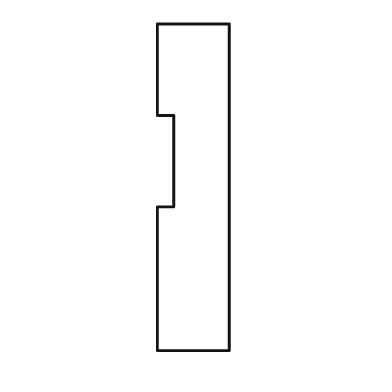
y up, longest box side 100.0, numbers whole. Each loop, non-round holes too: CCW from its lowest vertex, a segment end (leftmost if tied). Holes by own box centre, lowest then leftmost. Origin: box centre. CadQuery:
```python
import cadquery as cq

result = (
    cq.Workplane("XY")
    .moveTo(-11.0, -50.0)
    .lineTo(11.0, -50.0)
    .lineTo(11.0, 50.0)
    .lineTo(-11.0, 50.0)
    .lineTo(-11.0, 22.0)
    .lineTo(-6.0, 22.0)
    .lineTo(-6.0, -6.0)
    .lineTo(-11.0, -6.0)
    .close()
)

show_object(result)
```